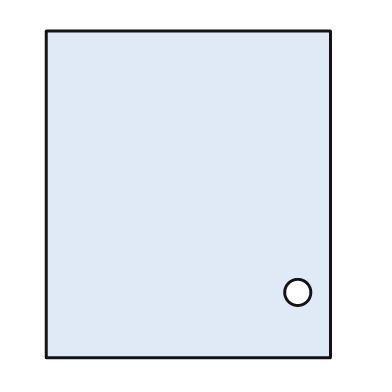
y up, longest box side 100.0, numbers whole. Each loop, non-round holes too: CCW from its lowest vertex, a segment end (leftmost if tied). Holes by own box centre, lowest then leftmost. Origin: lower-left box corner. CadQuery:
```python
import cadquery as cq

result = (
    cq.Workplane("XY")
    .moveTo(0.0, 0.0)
    .lineTo(87.0, 0.0)
    .lineTo(87.0, 100.0)
    .lineTo(0.0, 100.0)
    .close()
    .moveTo(77.0, 20.0)
    .circle(4.0)
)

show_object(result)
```